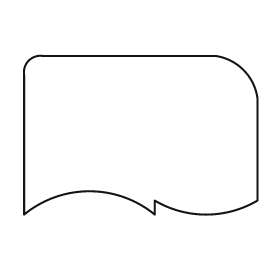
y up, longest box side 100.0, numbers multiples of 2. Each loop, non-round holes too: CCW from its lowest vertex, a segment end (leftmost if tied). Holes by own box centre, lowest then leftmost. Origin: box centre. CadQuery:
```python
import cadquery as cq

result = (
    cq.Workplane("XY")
    .moveTo(-50.0, -34.0)
    .threePointArc((-22.0, -24.0), (6.0, -34.0))
    .lineTo(6.0, -28.0)
    .threePointArc((28.0, -34.0), (50.0, -28.0))
    .lineTo(50.0, 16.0)
    .threePointArc((44.0, 28.0), (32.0, 34.0))
    .lineTo(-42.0, 34.0)
    .threePointArc((-48.0, 32.0), (-50.0, 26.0))
    .close()
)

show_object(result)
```